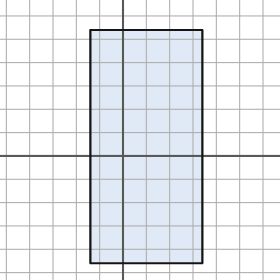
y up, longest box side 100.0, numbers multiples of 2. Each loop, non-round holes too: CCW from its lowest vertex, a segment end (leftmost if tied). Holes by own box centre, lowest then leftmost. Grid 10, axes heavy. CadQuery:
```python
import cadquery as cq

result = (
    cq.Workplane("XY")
    .moveTo(-14.0, -46.0)
    .lineTo(34.0, -46.0)
    .lineTo(34.0, 54.0)
    .lineTo(-14.0, 54.0)
    .close()
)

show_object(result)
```